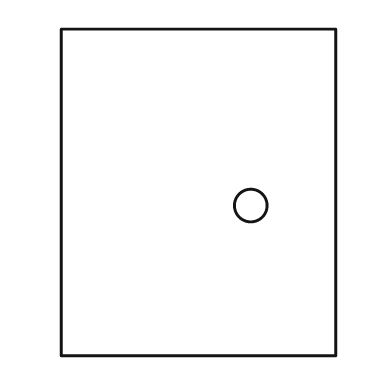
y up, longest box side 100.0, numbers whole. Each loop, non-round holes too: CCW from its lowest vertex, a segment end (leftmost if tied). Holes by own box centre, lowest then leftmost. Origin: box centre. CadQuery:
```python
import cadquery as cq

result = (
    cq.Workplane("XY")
    .moveTo(-42.0, -50.0)
    .lineTo(42.0, -50.0)
    .lineTo(42.0, 50.0)
    .lineTo(-42.0, 50.0)
    .close()
    .moveTo(16.0, -4.0)
    .circle(5.0)
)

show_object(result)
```